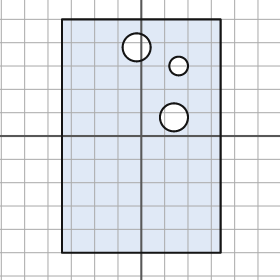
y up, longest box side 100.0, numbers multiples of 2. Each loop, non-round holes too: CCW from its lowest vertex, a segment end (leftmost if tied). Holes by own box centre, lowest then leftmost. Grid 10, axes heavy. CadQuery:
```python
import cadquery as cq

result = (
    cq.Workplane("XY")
    .moveTo(-34.0, -50.0)
    .lineTo(34.0, -50.0)
    .lineTo(34.0, 50.0)
    .lineTo(-34.0, 50.0)
    .close()
    .moveTo(14.0, 8.0)
    .circle(6.0)
    .moveTo(16.0, 30.0)
    .circle(4.0)
    .moveTo(-2.0, 38.0)
    .circle(6.0)
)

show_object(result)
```